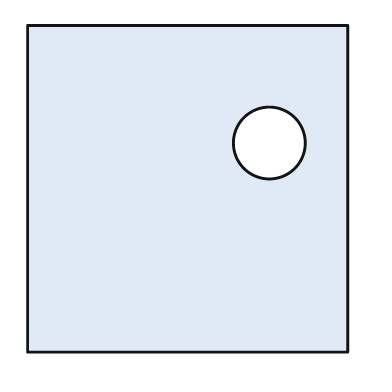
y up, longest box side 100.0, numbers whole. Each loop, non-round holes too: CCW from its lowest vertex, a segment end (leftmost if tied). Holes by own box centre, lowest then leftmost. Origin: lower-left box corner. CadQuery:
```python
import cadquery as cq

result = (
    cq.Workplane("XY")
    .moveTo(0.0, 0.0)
    .lineTo(98.0, 0.0)
    .lineTo(98.0, 100.0)
    .lineTo(0.0, 100.0)
    .close()
    .moveTo(74.0, 64.0)
    .circle(11.0)
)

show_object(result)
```